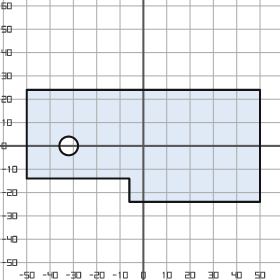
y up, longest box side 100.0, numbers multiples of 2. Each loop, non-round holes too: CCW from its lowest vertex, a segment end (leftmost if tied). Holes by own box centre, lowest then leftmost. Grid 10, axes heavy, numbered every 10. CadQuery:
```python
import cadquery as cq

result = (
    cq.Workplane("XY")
    .moveTo(-6.0, -24.0)
    .lineTo(50.0, -24.0)
    .lineTo(50.0, 24.0)
    .lineTo(-50.0, 24.0)
    .lineTo(-50.0, -14.0)
    .lineTo(-6.0, -14.0)
    .close()
    .moveTo(-32.0, 0.0)
    .circle(4.0)
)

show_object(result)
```